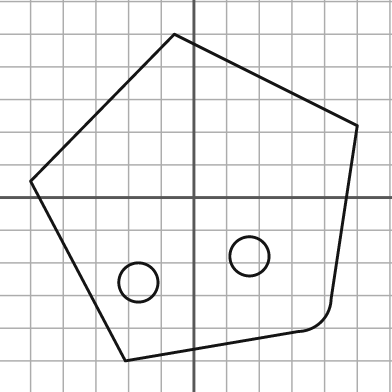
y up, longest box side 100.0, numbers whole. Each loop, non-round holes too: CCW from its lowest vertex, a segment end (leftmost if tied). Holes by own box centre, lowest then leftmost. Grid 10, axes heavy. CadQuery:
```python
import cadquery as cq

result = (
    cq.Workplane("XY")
    .moveTo(-21.0, -50.0)
    .lineTo(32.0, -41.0)
    .threePointArc((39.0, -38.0), (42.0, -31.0))
    .lineTo(50.0, 22.0)
    .lineTo(-6.0, 50.0)
    .lineTo(-50.0, 5.0)
    .close()
    .moveTo(-17.0, -26.0)
    .circle(6.0)
    .moveTo(17.0, -18.0)
    .circle(6.0)
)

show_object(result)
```